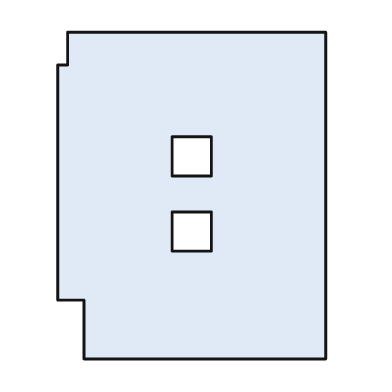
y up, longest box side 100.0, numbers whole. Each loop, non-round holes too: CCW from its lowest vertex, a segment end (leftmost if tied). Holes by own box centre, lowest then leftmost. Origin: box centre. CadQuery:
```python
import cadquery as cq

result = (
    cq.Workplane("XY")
    .moveTo(-33.0, -50.0)
    .lineTo(41.0, -50.0)
    .lineTo(41.0, 50.0)
    .lineTo(-38.0, 50.0)
    .lineTo(-38.0, 40.0)
    .lineTo(-41.0, 40.0)
    .lineTo(-41.0, -32.0)
    .lineTo(-33.0, -32.0)
    .close()
    .moveTo(-6.0, -17.0)
    .lineTo(6.0, -17.0)
    .lineTo(6.0, -5.0)
    .lineTo(-6.0, -5.0)
    .close()
    .moveTo(-6.0, 6.0)
    .lineTo(6.0, 6.0)
    .lineTo(6.0, 18.0)
    .lineTo(-6.0, 18.0)
    .close()
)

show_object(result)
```